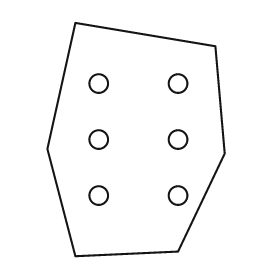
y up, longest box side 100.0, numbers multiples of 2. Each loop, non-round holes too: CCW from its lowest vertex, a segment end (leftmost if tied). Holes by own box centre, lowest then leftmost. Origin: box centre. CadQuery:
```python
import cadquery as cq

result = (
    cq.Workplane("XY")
    .moveTo(-26.0, -50.0)
    .lineTo(18.0, -48.0)
    .lineTo(38.0, -6.0)
    .lineTo(34.0, 40.0)
    .lineTo(-26.0, 50.0)
    .lineTo(-38.0, -4.0)
    .close()
    .moveTo(-16.0, -24.0)
    .circle(4.0)
    .moveTo(18.0, -24.0)
    .circle(4.0)
    .moveTo(-16.0, 0.0)
    .circle(4.0)
    .moveTo(18.0, 0.0)
    .circle(4.0)
    .moveTo(-16.0, 24.0)
    .circle(4.0)
    .moveTo(18.0, 24.0)
    .circle(4.0)
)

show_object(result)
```